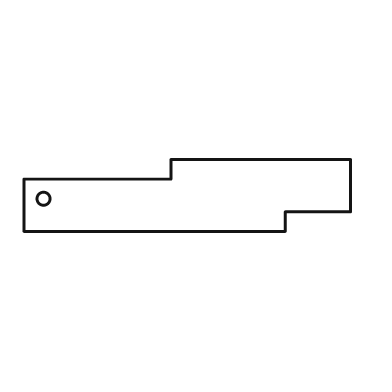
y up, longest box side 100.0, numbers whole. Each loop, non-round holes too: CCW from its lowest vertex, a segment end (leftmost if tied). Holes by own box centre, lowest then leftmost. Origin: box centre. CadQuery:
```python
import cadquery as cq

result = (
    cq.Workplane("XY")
    .moveTo(-50.0, -11.0)
    .lineTo(30.0, -11.0)
    .lineTo(30.0, -5.0)
    .lineTo(50.0, -5.0)
    .lineTo(50.0, 11.0)
    .lineTo(-5.0, 11.0)
    .lineTo(-5.0, 5.0)
    .lineTo(-50.0, 5.0)
    .close()
    .moveTo(-44.0, -1.0)
    .circle(2.0)
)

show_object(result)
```